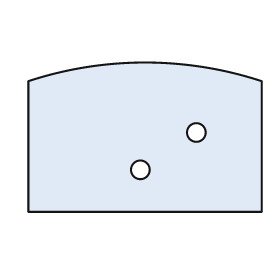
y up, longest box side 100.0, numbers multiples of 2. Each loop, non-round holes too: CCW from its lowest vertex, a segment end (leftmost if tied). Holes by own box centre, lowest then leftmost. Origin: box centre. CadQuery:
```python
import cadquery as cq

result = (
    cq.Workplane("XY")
    .moveTo(-50.0, -32.0)
    .lineTo(50.0, -32.0)
    .lineTo(50.0, 24.0)
    .threePointArc((0.0, 32.0), (-50.0, 24.0))
    .close()
    .moveTo(-2.0, -14.0)
    .circle(4.0)
    .moveTo(22.0, 2.0)
    .circle(4.0)
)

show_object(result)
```